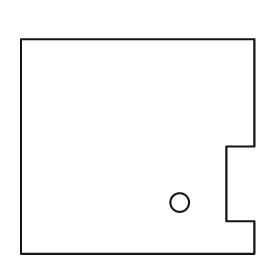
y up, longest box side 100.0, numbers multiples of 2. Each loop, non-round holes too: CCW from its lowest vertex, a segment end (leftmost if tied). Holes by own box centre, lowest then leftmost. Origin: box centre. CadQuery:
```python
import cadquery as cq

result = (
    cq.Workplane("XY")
    .moveTo(-50.0, -46.0)
    .lineTo(50.0, -46.0)
    .lineTo(50.0, -32.0)
    .lineTo(38.0, -32.0)
    .lineTo(38.0, 0.0)
    .lineTo(50.0, 0.0)
    .lineTo(50.0, 46.0)
    .lineTo(-50.0, 46.0)
    .close()
    .moveTo(18.0, -24.0)
    .circle(4.0)
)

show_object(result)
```